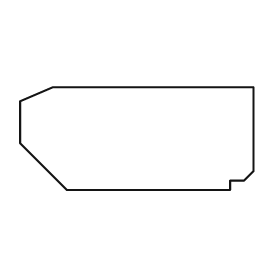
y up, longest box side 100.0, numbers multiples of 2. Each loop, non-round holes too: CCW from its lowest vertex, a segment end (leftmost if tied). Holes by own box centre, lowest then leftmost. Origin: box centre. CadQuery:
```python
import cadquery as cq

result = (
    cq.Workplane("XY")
    .moveTo(-30.0, -22.0)
    .lineTo(40.0, -22.0)
    .lineTo(40.0, -18.0)
    .lineTo(46.0, -18.0)
    .lineTo(50.0, -14.0)
    .lineTo(50.0, 22.0)
    .lineTo(-36.0, 22.0)
    .lineTo(-50.0, 16.0)
    .lineTo(-50.0, -2.0)
    .close()
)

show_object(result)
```